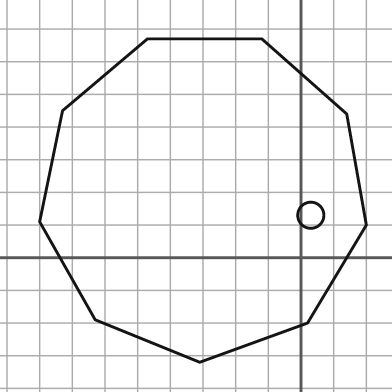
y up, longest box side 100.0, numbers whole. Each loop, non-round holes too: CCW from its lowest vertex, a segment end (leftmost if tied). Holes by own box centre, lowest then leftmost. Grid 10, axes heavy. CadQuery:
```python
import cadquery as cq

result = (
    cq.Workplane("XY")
    .moveTo(-31.0, -32.0)
    .lineTo(2.0, -20.0)
    .lineTo(20.0, 10.0)
    .lineTo(14.0, 44.0)
    .lineTo(-12.0, 67.0)
    .lineTo(-47.0, 67.0)
    .lineTo(-73.0, 45.0)
    .lineTo(-80.0, 11.0)
    .lineTo(-63.0, -19.0)
    .close()
    .moveTo(3.0, 13.0)
    .circle(4.0)
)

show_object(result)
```